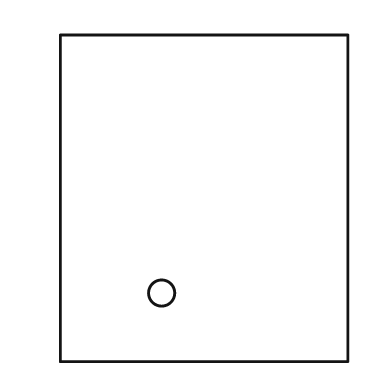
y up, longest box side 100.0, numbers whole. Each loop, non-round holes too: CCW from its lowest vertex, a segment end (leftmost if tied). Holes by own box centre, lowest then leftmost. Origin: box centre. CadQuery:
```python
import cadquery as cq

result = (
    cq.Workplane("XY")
    .moveTo(-44.0, -50.0)
    .lineTo(44.0, -50.0)
    .lineTo(44.0, 50.0)
    .lineTo(-44.0, 50.0)
    .close()
    .moveTo(-13.0, -29.0)
    .circle(4.0)
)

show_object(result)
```